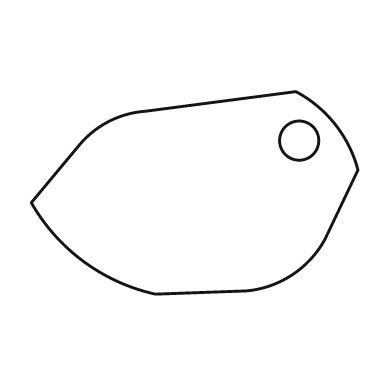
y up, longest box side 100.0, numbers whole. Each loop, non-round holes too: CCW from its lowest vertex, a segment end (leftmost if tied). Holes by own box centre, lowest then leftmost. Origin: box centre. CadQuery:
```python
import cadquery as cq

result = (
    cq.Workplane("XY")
    .moveTo(-12.0, -31.0)
    .lineTo(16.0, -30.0)
    .threePointArc((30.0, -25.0), (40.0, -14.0))
    .lineTo(50.0, 7.0)
    .threePointArc((43.0, 21.0), (31.0, 31.0))
    .lineTo(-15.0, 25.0)
    .threePointArc((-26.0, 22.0), (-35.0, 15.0))
    .lineTo(-50.0, -3.0)
    .threePointArc((-34.0, -21.0), (-12.0, -31.0))
    .close()
    .moveTo(32.0, 16.0)
    .circle(6.0)
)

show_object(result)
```